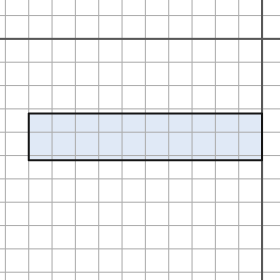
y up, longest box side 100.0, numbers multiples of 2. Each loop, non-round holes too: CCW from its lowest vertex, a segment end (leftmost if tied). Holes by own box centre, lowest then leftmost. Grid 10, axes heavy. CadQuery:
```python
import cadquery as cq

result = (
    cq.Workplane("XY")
    .moveTo(-100.0, -52.0)
    .lineTo(0.0, -52.0)
    .lineTo(0.0, -32.0)
    .lineTo(-100.0, -32.0)
    .close()
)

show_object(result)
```